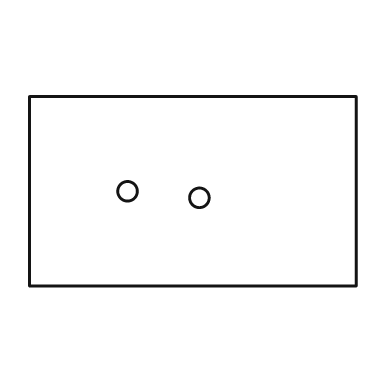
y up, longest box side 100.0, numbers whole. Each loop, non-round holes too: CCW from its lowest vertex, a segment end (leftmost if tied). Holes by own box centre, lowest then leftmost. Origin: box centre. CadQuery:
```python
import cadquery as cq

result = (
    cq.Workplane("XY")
    .moveTo(-50.0, -29.0)
    .lineTo(50.0, -29.0)
    .lineTo(50.0, 29.0)
    .lineTo(-50.0, 29.0)
    .close()
    .moveTo(2.0, -2.0)
    .circle(3.0)
    .moveTo(-20.0, 0.0)
    .circle(3.0)
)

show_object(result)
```